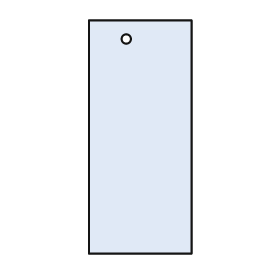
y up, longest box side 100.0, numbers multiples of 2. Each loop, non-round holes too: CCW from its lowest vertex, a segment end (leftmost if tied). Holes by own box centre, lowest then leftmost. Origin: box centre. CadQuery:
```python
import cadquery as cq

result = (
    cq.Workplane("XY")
    .moveTo(-22.0, -50.0)
    .lineTo(22.0, -50.0)
    .lineTo(22.0, 50.0)
    .lineTo(-22.0, 50.0)
    .close()
    .moveTo(-6.0, 42.0)
    .circle(2.0)
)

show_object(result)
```